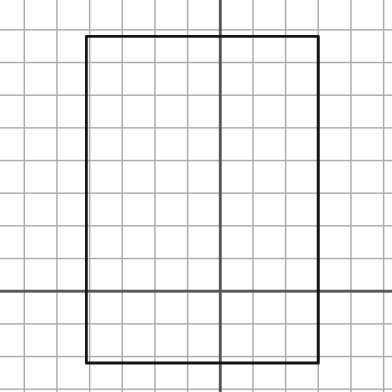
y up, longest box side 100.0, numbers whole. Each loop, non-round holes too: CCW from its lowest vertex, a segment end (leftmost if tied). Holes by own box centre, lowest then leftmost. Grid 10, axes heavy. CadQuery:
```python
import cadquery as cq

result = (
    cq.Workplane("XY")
    .moveTo(-41.0, -22.0)
    .lineTo(30.0, -22.0)
    .lineTo(30.0, 78.0)
    .lineTo(-41.0, 78.0)
    .close()
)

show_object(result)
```